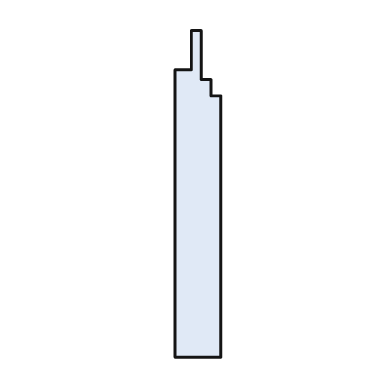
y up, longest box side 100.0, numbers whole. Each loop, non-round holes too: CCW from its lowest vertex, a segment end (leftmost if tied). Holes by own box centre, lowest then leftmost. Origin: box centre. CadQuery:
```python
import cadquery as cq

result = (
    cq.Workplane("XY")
    .moveTo(-7.0, -50.0)
    .lineTo(7.0, -50.0)
    .lineTo(7.0, 30.0)
    .lineTo(4.0, 30.0)
    .lineTo(4.0, 35.0)
    .lineTo(1.0, 35.0)
    .lineTo(1.0, 50.0)
    .lineTo(-2.0, 50.0)
    .lineTo(-2.0, 38.0)
    .lineTo(-7.0, 38.0)
    .close()
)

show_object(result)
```